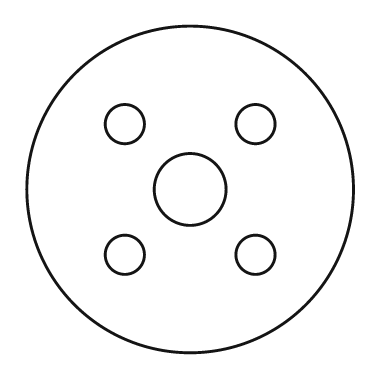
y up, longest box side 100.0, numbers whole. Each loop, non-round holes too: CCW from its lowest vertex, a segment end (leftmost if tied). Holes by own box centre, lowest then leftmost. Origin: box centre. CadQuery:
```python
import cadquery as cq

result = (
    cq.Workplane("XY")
    .moveTo(0.0, 0.0)
    .circle(50.0)
    .moveTo(-20.0, -20.0)
    .circle(6.0)
    .moveTo(20.0, -20.0)
    .circle(6.0)
    .moveTo(0.0, 0.0)
    .circle(11.0)
    .moveTo(-20.0, 20.0)
    .circle(6.0)
    .moveTo(20.0, 20.0)
    .circle(6.0)
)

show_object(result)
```